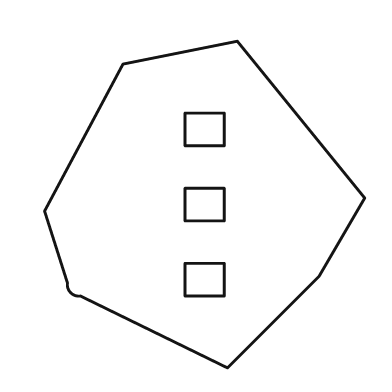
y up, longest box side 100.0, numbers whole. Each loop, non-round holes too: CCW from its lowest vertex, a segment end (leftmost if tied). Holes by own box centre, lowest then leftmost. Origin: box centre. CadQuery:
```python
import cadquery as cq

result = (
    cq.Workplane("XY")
    .moveTo(7.0, -50.0)
    .lineTo(35.0, -22.0)
    .lineTo(49.0, 2.0)
    .lineTo(10.0, 50.0)
    .lineTo(-25.0, 43.0)
    .lineTo(-49.0, -2.0)
    .lineTo(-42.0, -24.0)
    .threePointArc((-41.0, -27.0), (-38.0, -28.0))
    .close()
    .moveTo(-6.0, -28.0)
    .lineTo(6.0, -28.0)
    .lineTo(6.0, -18.0)
    .lineTo(-6.0, -18.0)
    .close()
    .moveTo(-6.0, -5.0)
    .lineTo(6.0, -5.0)
    .lineTo(6.0, 5.0)
    .lineTo(-6.0, 5.0)
    .close()
    .moveTo(-6.0, 18.0)
    .lineTo(6.0, 18.0)
    .lineTo(6.0, 28.0)
    .lineTo(-6.0, 28.0)
    .close()
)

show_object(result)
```